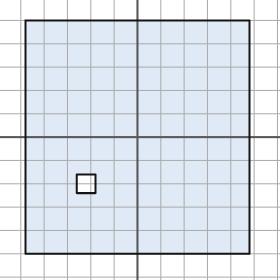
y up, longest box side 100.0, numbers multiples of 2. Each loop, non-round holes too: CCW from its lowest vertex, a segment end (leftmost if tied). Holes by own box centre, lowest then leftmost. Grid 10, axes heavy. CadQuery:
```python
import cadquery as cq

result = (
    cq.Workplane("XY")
    .moveTo(-48.0, -50.0)
    .lineTo(48.0, -50.0)
    .lineTo(48.0, 50.0)
    .lineTo(-48.0, 50.0)
    .close()
    .moveTo(-26.0, -24.0)
    .lineTo(-18.0, -24.0)
    .lineTo(-18.0, -16.0)
    .lineTo(-26.0, -16.0)
    .close()
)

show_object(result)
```